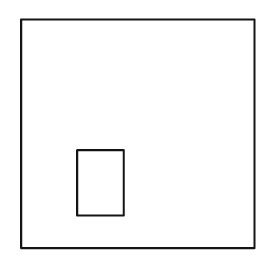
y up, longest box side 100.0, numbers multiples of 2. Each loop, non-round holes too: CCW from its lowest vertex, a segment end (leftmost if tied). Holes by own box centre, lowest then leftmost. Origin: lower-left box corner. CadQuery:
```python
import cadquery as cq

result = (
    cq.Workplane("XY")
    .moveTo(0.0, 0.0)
    .lineTo(100.0, 0.0)
    .lineTo(100.0, 98.0)
    .lineTo(0.0, 98.0)
    .close()
    .moveTo(24.0, 14.0)
    .lineTo(44.0, 14.0)
    .lineTo(44.0, 42.0)
    .lineTo(24.0, 42.0)
    .close()
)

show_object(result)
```